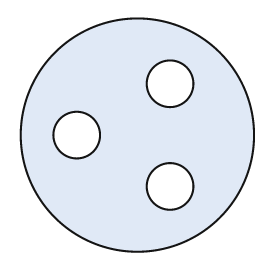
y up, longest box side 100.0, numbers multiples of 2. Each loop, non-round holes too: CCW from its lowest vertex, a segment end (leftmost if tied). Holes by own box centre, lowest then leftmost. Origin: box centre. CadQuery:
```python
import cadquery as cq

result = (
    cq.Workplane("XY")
    .moveTo(0.0, 0.0)
    .circle(50.0)
    .moveTo(14.0, -22.0)
    .circle(10.0)
    .moveTo(-26.0, 0.0)
    .circle(10.0)
    .moveTo(14.0, 22.0)
    .circle(10.0)
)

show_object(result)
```